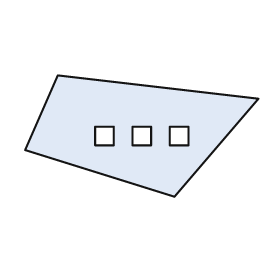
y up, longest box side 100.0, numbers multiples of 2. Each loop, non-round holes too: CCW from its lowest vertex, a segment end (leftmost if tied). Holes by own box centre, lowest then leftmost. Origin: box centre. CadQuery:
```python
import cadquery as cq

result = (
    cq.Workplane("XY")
    .moveTo(14.0, -26.0)
    .lineTo(50.0, 16.0)
    .lineTo(-36.0, 26.0)
    .lineTo(-50.0, -6.0)
    .close()
    .moveTo(-20.0, -4.0)
    .lineTo(-12.0, -4.0)
    .lineTo(-12.0, 4.0)
    .lineTo(-20.0, 4.0)
    .close()
    .moveTo(-4.0, -4.0)
    .lineTo(4.0, -4.0)
    .lineTo(4.0, 4.0)
    .lineTo(-4.0, 4.0)
    .close()
    .moveTo(12.0, -4.0)
    .lineTo(20.0, -4.0)
    .lineTo(20.0, 4.0)
    .lineTo(12.0, 4.0)
    .close()
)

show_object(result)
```